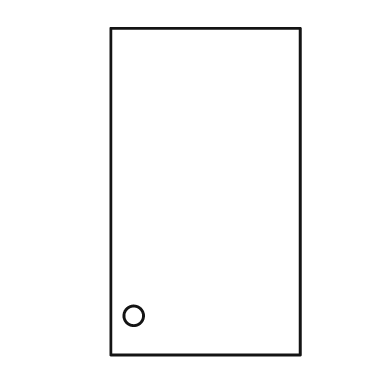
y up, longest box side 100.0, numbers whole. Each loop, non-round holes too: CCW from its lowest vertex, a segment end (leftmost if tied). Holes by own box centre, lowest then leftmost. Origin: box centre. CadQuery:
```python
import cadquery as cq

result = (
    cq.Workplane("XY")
    .moveTo(-29.0, -50.0)
    .lineTo(29.0, -50.0)
    .lineTo(29.0, 50.0)
    .lineTo(-29.0, 50.0)
    .close()
    .moveTo(-22.0, -38.0)
    .circle(3.0)
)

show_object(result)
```